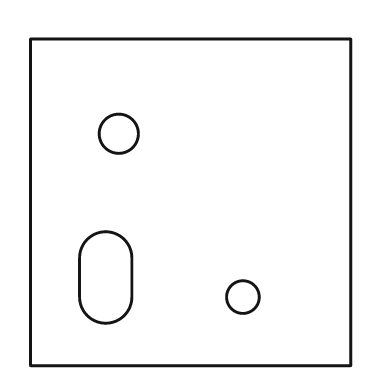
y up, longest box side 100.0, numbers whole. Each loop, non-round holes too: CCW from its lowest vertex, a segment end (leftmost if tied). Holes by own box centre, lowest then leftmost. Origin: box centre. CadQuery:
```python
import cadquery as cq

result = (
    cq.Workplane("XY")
    .moveTo(-49.0, -50.0)
    .lineTo(49.0, -50.0)
    .lineTo(49.0, 50.0)
    .lineTo(-49.0, 50.0)
    .close()
    .moveTo(16.0, -29.0)
    .circle(5.0)
    .moveTo(-34.0, -29.0)
    .threePointArc((-26.0, -37.0), (-18.0, -29.0))
    .lineTo(-18.0, -17.0)
    .threePointArc((-26.0, -9.0), (-34.0, -17.0))
    .close()
    .moveTo(-22.0, 21.0)
    .circle(6.0)
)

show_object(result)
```